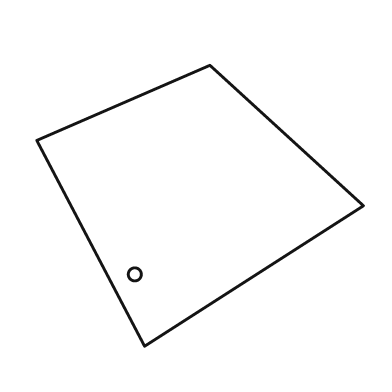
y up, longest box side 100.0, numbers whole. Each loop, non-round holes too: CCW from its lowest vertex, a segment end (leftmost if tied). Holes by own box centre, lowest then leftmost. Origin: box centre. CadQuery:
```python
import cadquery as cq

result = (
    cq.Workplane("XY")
    .moveTo(-17.0, -43.0)
    .lineTo(50.0, 0.0)
    .lineTo(3.0, 43.0)
    .lineTo(-50.0, 20.0)
    .close()
    .moveTo(-20.0, -21.0)
    .circle(2.0)
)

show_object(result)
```